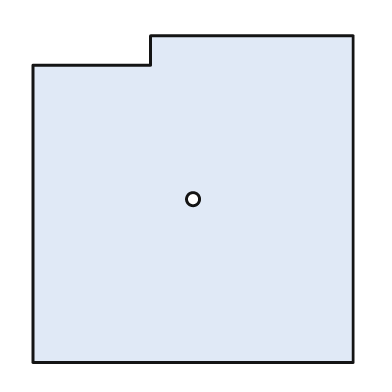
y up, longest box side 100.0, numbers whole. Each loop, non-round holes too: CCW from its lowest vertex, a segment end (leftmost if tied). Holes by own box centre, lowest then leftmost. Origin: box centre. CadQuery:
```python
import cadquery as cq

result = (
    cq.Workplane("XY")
    .moveTo(-49.0, -50.0)
    .lineTo(49.0, -50.0)
    .lineTo(49.0, 50.0)
    .lineTo(-13.0, 50.0)
    .lineTo(-13.0, 41.0)
    .lineTo(-49.0, 41.0)
    .close()
    .moveTo(0.0, 0.0)
    .circle(2.0)
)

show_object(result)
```